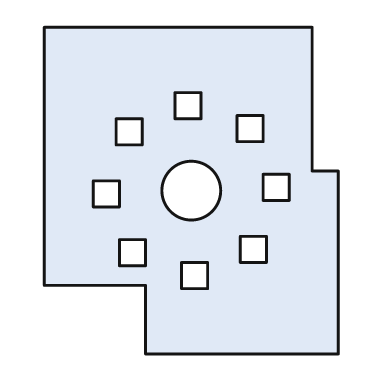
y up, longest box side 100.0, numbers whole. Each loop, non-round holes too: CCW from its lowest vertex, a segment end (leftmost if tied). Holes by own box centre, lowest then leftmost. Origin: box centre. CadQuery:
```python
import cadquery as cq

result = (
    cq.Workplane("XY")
    .moveTo(-14.0, -50.0)
    .lineTo(45.0, -50.0)
    .lineTo(45.0, 6.0)
    .lineTo(37.0, 6.0)
    .lineTo(37.0, 50.0)
    .lineTo(-45.0, 50.0)
    .lineTo(-45.0, -29.0)
    .lineTo(-14.0, -29.0)
    .close()
    .moveTo(-3.0, -30.0)
    .lineTo(5.0, -30.0)
    .lineTo(5.0, -22.0)
    .lineTo(-3.0, -22.0)
    .close()
    .moveTo(-22.0, -23.0)
    .lineTo(-14.0, -23.0)
    .lineTo(-14.0, -15.0)
    .lineTo(-22.0, -15.0)
    .close()
    .moveTo(15.0, -22.0)
    .lineTo(23.0, -22.0)
    .lineTo(23.0, -14.0)
    .lineTo(15.0, -14.0)
    .close()
    .moveTo(-30.0, -5.0)
    .lineTo(-22.0, -5.0)
    .lineTo(-22.0, 3.0)
    .lineTo(-30.0, 3.0)
    .close()
    .moveTo(0.0, 0.0)
    .circle(9.0)
    .moveTo(22.0, -3.0)
    .lineTo(30.0, -3.0)
    .lineTo(30.0, 5.0)
    .lineTo(22.0, 5.0)
    .close()
    .moveTo(-23.0, 14.0)
    .lineTo(-15.0, 14.0)
    .lineTo(-15.0, 22.0)
    .lineTo(-23.0, 22.0)
    .close()
    .moveTo(14.0, 15.0)
    .lineTo(22.0, 15.0)
    .lineTo(22.0, 23.0)
    .lineTo(14.0, 23.0)
    .close()
    .moveTo(-5.0, 22.0)
    .lineTo(3.0, 22.0)
    .lineTo(3.0, 30.0)
    .lineTo(-5.0, 30.0)
    .close()
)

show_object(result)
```